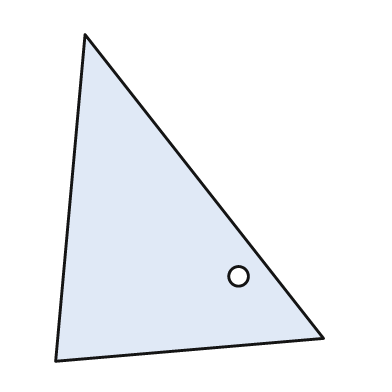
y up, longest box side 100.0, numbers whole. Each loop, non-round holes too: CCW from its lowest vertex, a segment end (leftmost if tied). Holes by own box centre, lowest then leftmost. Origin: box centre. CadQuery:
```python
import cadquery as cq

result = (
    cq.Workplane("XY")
    .moveTo(-41.0, -50.0)
    .lineTo(41.0, -43.0)
    .lineTo(-32.0, 50.0)
    .close()
    .moveTo(15.0, -24.0)
    .circle(3.0)
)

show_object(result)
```